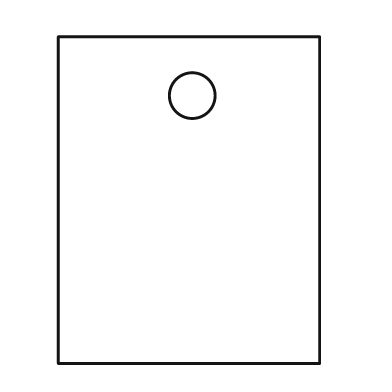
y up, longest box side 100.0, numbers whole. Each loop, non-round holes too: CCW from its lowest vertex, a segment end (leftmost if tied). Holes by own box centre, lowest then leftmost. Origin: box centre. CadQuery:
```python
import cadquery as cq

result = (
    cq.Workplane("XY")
    .moveTo(-40.0, -50.0)
    .lineTo(40.0, -50.0)
    .lineTo(40.0, 50.0)
    .lineTo(-40.0, 50.0)
    .close()
    .moveTo(1.0, 32.0)
    .circle(7.0)
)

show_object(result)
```